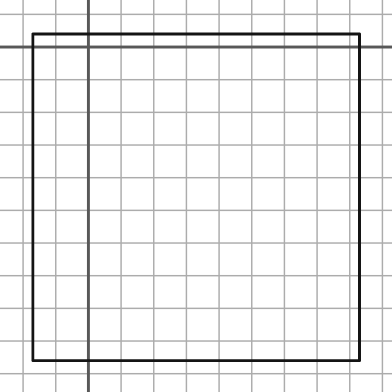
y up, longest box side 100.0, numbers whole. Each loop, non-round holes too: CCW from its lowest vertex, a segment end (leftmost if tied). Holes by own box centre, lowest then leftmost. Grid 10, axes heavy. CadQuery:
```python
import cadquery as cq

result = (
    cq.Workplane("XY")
    .moveTo(-17.0, -96.0)
    .lineTo(83.0, -96.0)
    .lineTo(83.0, 4.0)
    .lineTo(-17.0, 4.0)
    .close()
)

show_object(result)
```